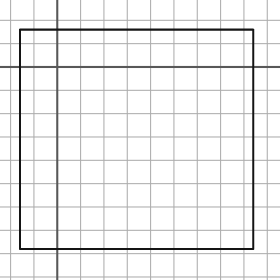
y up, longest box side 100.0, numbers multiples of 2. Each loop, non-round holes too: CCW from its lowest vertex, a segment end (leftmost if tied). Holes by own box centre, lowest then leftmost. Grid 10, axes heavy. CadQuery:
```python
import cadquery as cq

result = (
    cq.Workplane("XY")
    .moveTo(-16.0, -78.0)
    .lineTo(84.0, -78.0)
    .lineTo(84.0, 16.0)
    .lineTo(-16.0, 16.0)
    .close()
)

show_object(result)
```